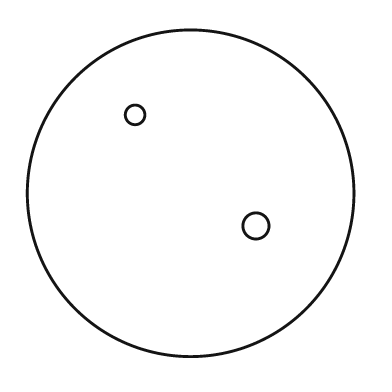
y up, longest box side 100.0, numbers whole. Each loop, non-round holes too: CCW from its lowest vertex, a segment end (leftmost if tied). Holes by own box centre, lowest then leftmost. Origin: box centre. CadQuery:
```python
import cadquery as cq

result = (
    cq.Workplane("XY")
    .moveTo(0.0, 0.0)
    .circle(50.0)
    .moveTo(20.0, -10.0)
    .circle(4.0)
    .moveTo(-17.0, 24.0)
    .circle(3.0)
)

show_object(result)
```